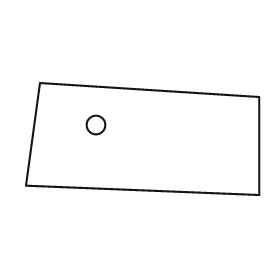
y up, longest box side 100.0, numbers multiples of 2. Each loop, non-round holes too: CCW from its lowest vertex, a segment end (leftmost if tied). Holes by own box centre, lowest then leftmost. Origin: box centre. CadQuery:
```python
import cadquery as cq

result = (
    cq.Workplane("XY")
    .moveTo(50.0, -24.0)
    .lineTo(50.0, 18.0)
    .lineTo(-44.0, 24.0)
    .lineTo(-50.0, -20.0)
    .close()
    .moveTo(-20.0, 6.0)
    .circle(4.0)
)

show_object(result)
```